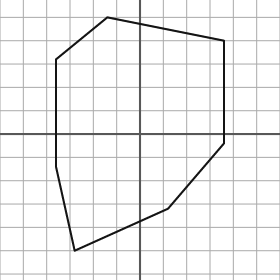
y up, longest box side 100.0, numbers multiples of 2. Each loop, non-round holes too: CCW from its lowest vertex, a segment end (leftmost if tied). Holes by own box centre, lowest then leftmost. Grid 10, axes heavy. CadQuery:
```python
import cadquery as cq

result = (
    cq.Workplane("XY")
    .moveTo(-28.0, -50.0)
    .lineTo(12.0, -32.0)
    .lineTo(36.0, -4.0)
    .lineTo(36.0, 40.0)
    .lineTo(-14.0, 50.0)
    .lineTo(-36.0, 32.0)
    .lineTo(-36.0, -14.0)
    .close()
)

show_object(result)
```